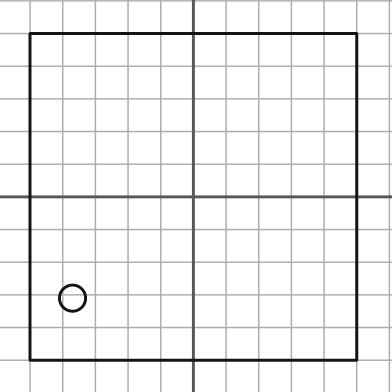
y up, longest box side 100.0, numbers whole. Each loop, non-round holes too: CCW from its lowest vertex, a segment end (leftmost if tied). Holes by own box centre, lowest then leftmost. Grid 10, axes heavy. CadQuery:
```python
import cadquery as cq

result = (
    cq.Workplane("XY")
    .moveTo(-50.0, -50.0)
    .lineTo(50.0, -50.0)
    .lineTo(50.0, 50.0)
    .lineTo(-50.0, 50.0)
    .close()
    .moveTo(-37.0, -31.0)
    .circle(4.0)
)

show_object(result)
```